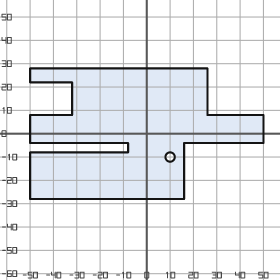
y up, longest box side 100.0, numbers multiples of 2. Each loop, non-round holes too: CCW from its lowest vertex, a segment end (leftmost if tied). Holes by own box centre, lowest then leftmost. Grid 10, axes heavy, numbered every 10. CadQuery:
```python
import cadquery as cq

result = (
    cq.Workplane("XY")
    .moveTo(-50.0, -28.0)
    .lineTo(16.0, -28.0)
    .lineTo(16.0, -4.0)
    .lineTo(50.0, -4.0)
    .lineTo(50.0, 8.0)
    .lineTo(26.0, 8.0)
    .lineTo(26.0, 28.0)
    .lineTo(-50.0, 28.0)
    .lineTo(-50.0, 22.0)
    .lineTo(-32.0, 22.0)
    .lineTo(-32.0, 8.0)
    .lineTo(-50.0, 8.0)
    .lineTo(-50.0, -4.0)
    .lineTo(-8.0, -4.0)
    .lineTo(-8.0, -8.0)
    .lineTo(-50.0, -8.0)
    .close()
    .moveTo(10.0, -10.0)
    .circle(2.0)
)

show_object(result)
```